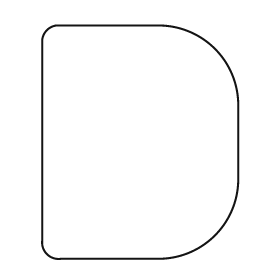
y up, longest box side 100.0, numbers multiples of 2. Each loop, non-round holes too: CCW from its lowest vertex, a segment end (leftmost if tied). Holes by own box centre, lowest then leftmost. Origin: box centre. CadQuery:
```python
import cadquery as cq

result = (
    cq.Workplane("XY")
    .moveTo(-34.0, -50.0)
    .lineTo(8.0, -50.0)
    .threePointArc((32.0, -40.0), (42.0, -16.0))
    .lineTo(42.0, 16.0)
    .threePointArc((32.0, 40.0), (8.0, 50.0))
    .lineTo(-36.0, 50.0)
    .threePointArc((-40.0, 48.0), (-42.0, 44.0))
    .lineTo(-42.0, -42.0)
    .threePointArc((-40.0, -48.0), (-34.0, -50.0))
    .close()
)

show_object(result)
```